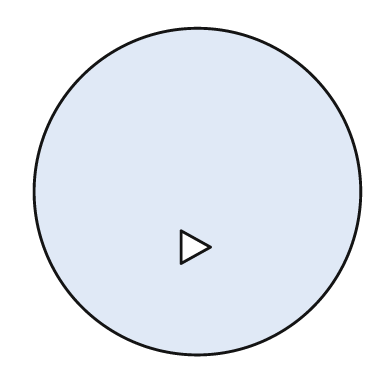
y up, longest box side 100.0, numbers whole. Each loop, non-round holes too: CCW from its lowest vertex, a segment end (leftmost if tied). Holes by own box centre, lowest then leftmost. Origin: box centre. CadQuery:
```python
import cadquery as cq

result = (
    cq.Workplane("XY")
    .moveTo(0.0, 0.0)
    .circle(50.0)
    .moveTo(-5.0, -22.0)
    .lineTo(4.0, -17.0)
    .lineTo(-5.0, -12.0)
    .close()
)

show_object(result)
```